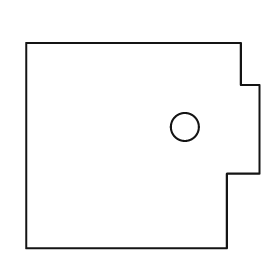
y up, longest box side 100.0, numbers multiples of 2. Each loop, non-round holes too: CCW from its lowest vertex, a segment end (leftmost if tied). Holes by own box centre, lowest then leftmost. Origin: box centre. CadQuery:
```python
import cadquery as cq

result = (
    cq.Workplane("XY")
    .moveTo(-50.0, -44.0)
    .lineTo(36.0, -44.0)
    .lineTo(36.0, -12.0)
    .lineTo(50.0, -12.0)
    .lineTo(50.0, 26.0)
    .lineTo(42.0, 26.0)
    .lineTo(42.0, 44.0)
    .lineTo(-50.0, 44.0)
    .close()
    .moveTo(18.0, 8.0)
    .circle(6.0)
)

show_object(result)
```